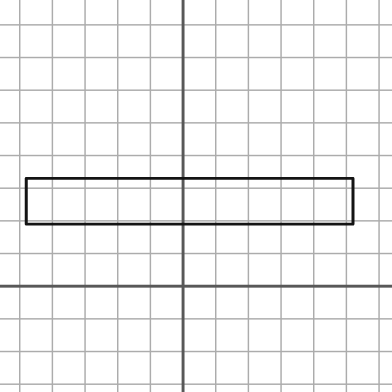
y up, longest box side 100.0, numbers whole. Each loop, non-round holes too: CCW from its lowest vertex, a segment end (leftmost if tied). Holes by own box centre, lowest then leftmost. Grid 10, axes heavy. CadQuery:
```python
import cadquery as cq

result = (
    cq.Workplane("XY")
    .moveTo(-48.0, 19.0)
    .lineTo(52.0, 19.0)
    .lineTo(52.0, 33.0)
    .lineTo(-48.0, 33.0)
    .close()
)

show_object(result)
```